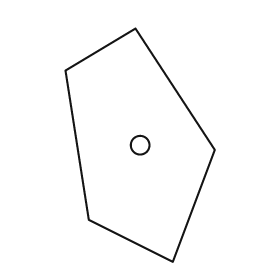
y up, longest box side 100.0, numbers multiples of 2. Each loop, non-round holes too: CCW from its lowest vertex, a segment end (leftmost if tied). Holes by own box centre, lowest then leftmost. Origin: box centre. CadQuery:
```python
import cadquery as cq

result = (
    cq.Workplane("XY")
    .moveTo(14.0, -50.0)
    .lineTo(32.0, -2.0)
    .lineTo(-2.0, 50.0)
    .lineTo(-32.0, 32.0)
    .lineTo(-22.0, -32.0)
    .close()
    .moveTo(0.0, 0.0)
    .circle(4.0)
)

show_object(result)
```